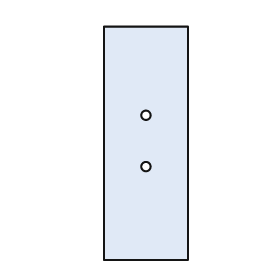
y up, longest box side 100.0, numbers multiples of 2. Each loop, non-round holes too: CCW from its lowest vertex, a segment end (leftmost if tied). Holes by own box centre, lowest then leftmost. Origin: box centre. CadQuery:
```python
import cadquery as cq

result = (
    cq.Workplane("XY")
    .moveTo(-18.0, -50.0)
    .lineTo(18.0, -50.0)
    .lineTo(18.0, 50.0)
    .lineTo(-18.0, 50.0)
    .close()
    .moveTo(0.0, -10.0)
    .circle(2.0)
    .moveTo(0.0, 12.0)
    .circle(2.0)
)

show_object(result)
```